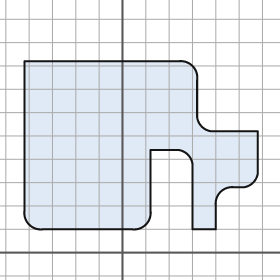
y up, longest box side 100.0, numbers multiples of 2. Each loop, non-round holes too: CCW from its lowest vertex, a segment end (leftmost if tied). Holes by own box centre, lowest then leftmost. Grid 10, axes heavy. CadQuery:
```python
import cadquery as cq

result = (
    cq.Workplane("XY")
    .moveTo(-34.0, 10.0)
    .lineTo(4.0, 10.0)
    .threePointArc((10.0, 12.0), (12.0, 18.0))
    .lineTo(12.0, 44.0)
    .lineTo(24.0, 44.0)
    .threePointArc((28.0, 42.0), (30.0, 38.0))
    .lineTo(30.0, 10.0)
    .lineTo(40.0, 10.0)
    .lineTo(40.0, 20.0)
    .threePointArc((42.0, 26.0), (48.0, 28.0))
    .lineTo(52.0, 28.0)
    .threePointArc((56.0, 30.0), (58.0, 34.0))
    .lineTo(58.0, 52.0)
    .lineTo(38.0, 52.0)
    .threePointArc((34.0, 54.0), (32.0, 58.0))
    .lineTo(32.0, 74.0)
    .threePointArc((30.0, 80.0), (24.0, 82.0))
    .lineTo(-42.0, 82.0)
    .lineTo(-42.0, 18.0)
    .threePointArc((-40.0, 12.0), (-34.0, 10.0))
    .close()
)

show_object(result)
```